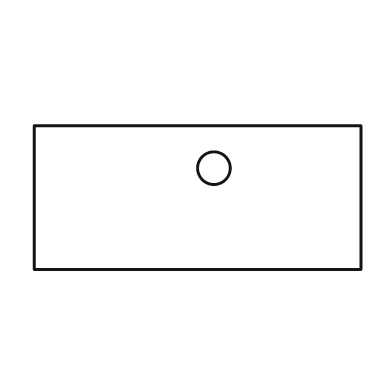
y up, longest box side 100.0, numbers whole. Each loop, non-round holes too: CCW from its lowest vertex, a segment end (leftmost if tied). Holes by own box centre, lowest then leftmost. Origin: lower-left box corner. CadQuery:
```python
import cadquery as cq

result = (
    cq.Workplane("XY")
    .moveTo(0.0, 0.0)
    .lineTo(100.0, 0.0)
    .lineTo(100.0, 44.0)
    .lineTo(0.0, 44.0)
    .close()
    .moveTo(55.0, 31.0)
    .circle(5.0)
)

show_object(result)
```